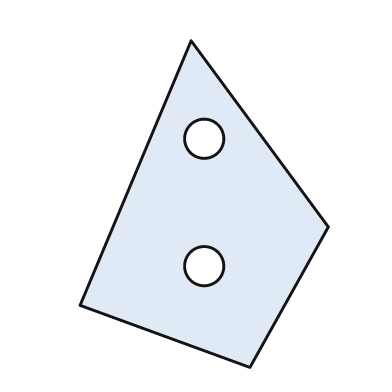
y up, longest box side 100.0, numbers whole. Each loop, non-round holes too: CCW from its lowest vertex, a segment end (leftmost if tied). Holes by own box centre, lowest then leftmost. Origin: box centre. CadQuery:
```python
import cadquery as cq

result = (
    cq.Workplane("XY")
    .moveTo(14.0, -50.0)
    .lineTo(38.0, -7.0)
    .lineTo(-4.0, 50.0)
    .lineTo(-38.0, -31.0)
    .close()
    .moveTo(0.0, -19.0)
    .circle(6.0)
    .moveTo(0.0, 20.0)
    .circle(6.0)
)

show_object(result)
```